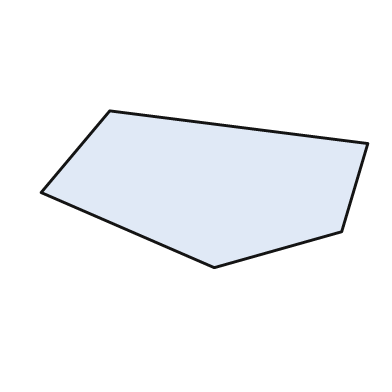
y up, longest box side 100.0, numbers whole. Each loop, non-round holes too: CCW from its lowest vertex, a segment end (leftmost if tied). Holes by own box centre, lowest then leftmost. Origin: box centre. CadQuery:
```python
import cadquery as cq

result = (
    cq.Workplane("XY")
    .moveTo(3.0, -24.0)
    .lineTo(42.0, -13.0)
    .lineTo(50.0, 14.0)
    .lineTo(-29.0, 24.0)
    .lineTo(-50.0, -1.0)
    .close()
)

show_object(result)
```